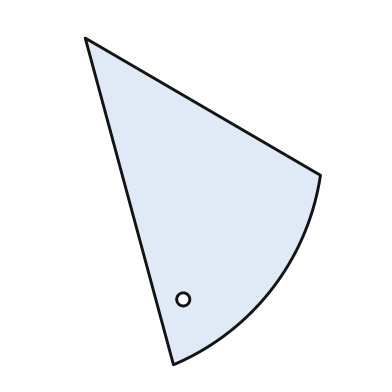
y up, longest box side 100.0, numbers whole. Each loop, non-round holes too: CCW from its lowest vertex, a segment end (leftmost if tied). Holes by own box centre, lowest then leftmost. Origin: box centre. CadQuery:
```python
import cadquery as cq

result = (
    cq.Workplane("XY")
    .moveTo(-9.0, -50.0)
    .threePointArc((21.0, -27.0), (36.0, 8.0))
    .lineTo(-36.0, 50.0)
    .close()
    .moveTo(-6.0, -30.0)
    .circle(2.0)
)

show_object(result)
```